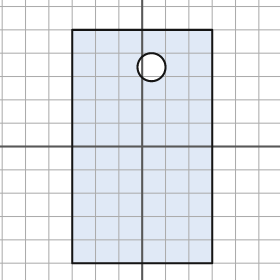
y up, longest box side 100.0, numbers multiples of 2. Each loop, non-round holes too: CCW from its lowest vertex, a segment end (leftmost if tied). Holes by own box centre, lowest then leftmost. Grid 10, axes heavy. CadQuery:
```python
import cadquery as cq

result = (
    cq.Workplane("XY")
    .moveTo(-30.0, -50.0)
    .lineTo(30.0, -50.0)
    .lineTo(30.0, 50.0)
    .lineTo(-30.0, 50.0)
    .close()
    .moveTo(4.0, 34.0)
    .circle(6.0)
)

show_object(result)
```